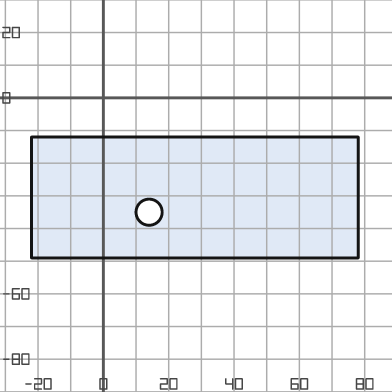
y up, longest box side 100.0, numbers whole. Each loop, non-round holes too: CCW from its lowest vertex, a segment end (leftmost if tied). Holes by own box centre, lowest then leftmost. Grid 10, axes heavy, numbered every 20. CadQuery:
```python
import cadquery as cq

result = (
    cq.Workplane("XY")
    .moveTo(-22.0, -49.0)
    .lineTo(78.0, -49.0)
    .lineTo(78.0, -12.0)
    .lineTo(-22.0, -12.0)
    .close()
    .moveTo(14.0, -35.0)
    .circle(4.0)
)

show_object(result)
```